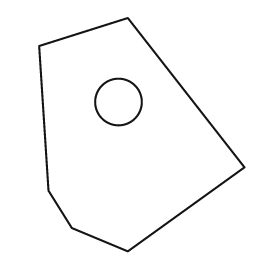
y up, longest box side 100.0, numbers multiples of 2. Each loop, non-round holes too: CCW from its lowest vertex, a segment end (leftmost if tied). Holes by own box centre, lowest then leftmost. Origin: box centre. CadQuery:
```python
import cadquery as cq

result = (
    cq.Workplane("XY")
    .moveTo(-6.0, -50.0)
    .lineTo(44.0, -14.0)
    .lineTo(-6.0, 50.0)
    .lineTo(-44.0, 38.0)
    .lineTo(-40.0, -24.0)
    .lineTo(-30.0, -40.0)
    .close()
    .moveTo(-10.0, 14.0)
    .circle(10.0)
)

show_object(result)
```